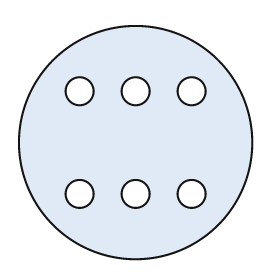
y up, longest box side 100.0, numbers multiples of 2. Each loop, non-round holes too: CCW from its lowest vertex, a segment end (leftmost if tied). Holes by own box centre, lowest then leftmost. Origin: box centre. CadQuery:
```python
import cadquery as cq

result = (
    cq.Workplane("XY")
    .moveTo(0.0, 0.0)
    .circle(50.0)
    .moveTo(-24.0, -22.0)
    .circle(6.0)
    .moveTo(0.0, -22.0)
    .circle(6.0)
    .moveTo(24.0, -22.0)
    .circle(6.0)
    .moveTo(-24.0, 22.0)
    .circle(6.0)
    .moveTo(0.0, 22.0)
    .circle(6.0)
    .moveTo(24.0, 22.0)
    .circle(6.0)
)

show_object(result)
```